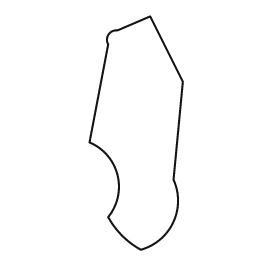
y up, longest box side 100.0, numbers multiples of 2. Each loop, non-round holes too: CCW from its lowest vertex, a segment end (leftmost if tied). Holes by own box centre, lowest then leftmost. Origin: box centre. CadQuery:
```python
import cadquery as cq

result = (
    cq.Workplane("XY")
    .moveTo(2.0, -50.0)
    .threePointArc((16.0, -38.0), (16.0, -20.0))
    .lineTo(20.0, 22.0)
    .lineTo(6.0, 50.0)
    .lineTo(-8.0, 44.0)
    .threePointArc((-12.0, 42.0), (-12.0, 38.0))
    .lineTo(-20.0, -4.0)
    .threePointArc((-8.0, -18.0), (-12.0, -36.0))
    .threePointArc((-6.0, -44.0), (2.0, -50.0))
    .close()
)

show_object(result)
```